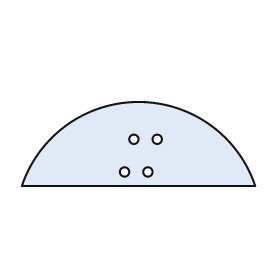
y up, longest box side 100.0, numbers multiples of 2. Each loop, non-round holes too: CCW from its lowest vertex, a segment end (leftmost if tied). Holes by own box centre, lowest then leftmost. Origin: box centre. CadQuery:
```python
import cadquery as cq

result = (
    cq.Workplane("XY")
    .moveTo(-50.0, -18.0)
    .lineTo(50.0, -18.0)
    .threePointArc((0.0, 18.0), (-50.0, -18.0))
    .close()
    .moveTo(-6.0, -12.0)
    .circle(2.0)
    .moveTo(4.0, -12.0)
    .circle(2.0)
    .moveTo(-2.0, 2.0)
    .circle(2.0)
    .moveTo(8.0, 2.0)
    .circle(2.0)
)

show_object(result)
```